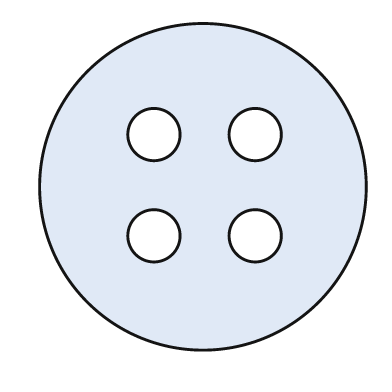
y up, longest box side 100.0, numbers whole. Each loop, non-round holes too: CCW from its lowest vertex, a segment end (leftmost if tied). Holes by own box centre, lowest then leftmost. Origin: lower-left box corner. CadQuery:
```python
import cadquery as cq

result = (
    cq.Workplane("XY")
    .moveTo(50.0, 50.0)
    .circle(50.0)
    .moveTo(35.0, 35.0)
    .circle(8.0)
    .moveTo(66.0, 35.0)
    .circle(8.0)
    .moveTo(35.0, 66.0)
    .circle(8.0)
    .moveTo(66.0, 66.0)
    .circle(8.0)
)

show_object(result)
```